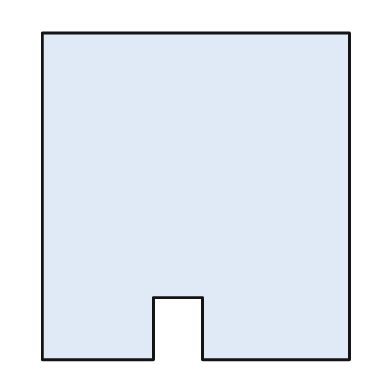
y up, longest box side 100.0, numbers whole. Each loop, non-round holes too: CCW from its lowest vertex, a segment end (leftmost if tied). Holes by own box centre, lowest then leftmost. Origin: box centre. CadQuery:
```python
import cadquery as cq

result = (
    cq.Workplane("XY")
    .moveTo(-47.0, -50.0)
    .lineTo(-13.0, -50.0)
    .lineTo(-13.0, -31.0)
    .lineTo(2.0, -31.0)
    .lineTo(2.0, -50.0)
    .lineTo(47.0, -50.0)
    .lineTo(47.0, 50.0)
    .lineTo(-47.0, 50.0)
    .close()
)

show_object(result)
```